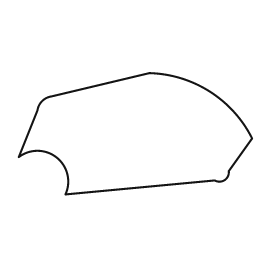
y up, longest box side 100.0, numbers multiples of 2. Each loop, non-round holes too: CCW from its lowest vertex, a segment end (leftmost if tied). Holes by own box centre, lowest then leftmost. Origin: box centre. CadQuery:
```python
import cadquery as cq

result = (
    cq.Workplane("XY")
    .moveTo(-30.0, -26.0)
    .lineTo(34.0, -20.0)
    .threePointArc((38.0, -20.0), (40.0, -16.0))
    .lineTo(50.0, -2.0)
    .threePointArc((32.0, 18.0), (6.0, 26.0))
    .lineTo(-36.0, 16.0)
    .threePointArc((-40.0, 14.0), (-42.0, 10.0))
    .lineTo(-50.0, -10.0)
    .threePointArc((-34.0, -10.0), (-30.0, -26.0))
    .close()
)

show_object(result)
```